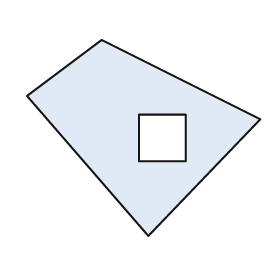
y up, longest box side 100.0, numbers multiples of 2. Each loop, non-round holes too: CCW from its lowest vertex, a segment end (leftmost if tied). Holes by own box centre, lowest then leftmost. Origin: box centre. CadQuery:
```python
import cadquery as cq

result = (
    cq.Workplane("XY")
    .moveTo(2.0, -42.0)
    .lineTo(50.0, 8.0)
    .lineTo(-18.0, 42.0)
    .lineTo(-50.0, 18.0)
    .close()
    .moveTo(-2.0, -10.0)
    .lineTo(18.0, -10.0)
    .lineTo(18.0, 10.0)
    .lineTo(-2.0, 10.0)
    .close()
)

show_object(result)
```